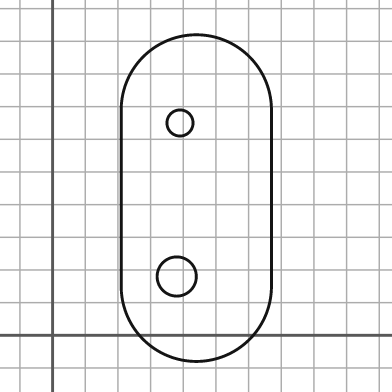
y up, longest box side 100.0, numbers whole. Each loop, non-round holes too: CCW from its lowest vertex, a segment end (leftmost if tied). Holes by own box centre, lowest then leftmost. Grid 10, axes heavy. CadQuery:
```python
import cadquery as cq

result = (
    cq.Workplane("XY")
    .moveTo(21.0, 15.0)
    .threePointArc((44.0, -8.0), (67.0, 15.0))
    .lineTo(67.0, 69.0)
    .threePointArc((44.0, 92.0), (21.0, 69.0))
    .close()
    .moveTo(38.0, 18.0)
    .circle(6.0)
    .moveTo(39.0, 65.0)
    .circle(4.0)
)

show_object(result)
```